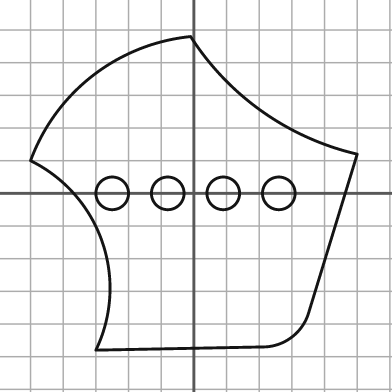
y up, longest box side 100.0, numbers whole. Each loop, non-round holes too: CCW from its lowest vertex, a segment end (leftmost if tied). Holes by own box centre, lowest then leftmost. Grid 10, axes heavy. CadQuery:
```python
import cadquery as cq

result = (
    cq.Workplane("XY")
    .moveTo(-30.0, -48.0)
    .lineTo(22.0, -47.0)
    .threePointArc((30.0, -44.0), (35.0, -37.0))
    .lineTo(50.0, 12.0)
    .threePointArc((21.0, 25.0), (-1.0, 48.0))
    .threePointArc((-31.0, 36.0), (-50.0, 10.0))
    .threePointArc((-28.0, -15.0), (-30.0, -48.0))
    .close()
    .moveTo(-25.0, 0.0)
    .circle(5.0)
    .moveTo(-8.0, 0.0)
    .circle(5.0)
    .moveTo(9.0, 0.0)
    .circle(5.0)
    .moveTo(26.0, 0.0)
    .circle(5.0)
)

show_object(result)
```